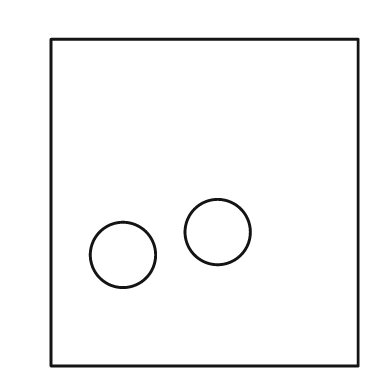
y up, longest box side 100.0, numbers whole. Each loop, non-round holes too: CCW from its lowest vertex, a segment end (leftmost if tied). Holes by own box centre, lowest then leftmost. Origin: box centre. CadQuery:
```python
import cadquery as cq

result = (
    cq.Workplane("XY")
    .moveTo(-47.0, -50.0)
    .lineTo(47.0, -50.0)
    .lineTo(47.0, 50.0)
    .lineTo(-47.0, 50.0)
    .close()
    .moveTo(-25.0, -16.0)
    .circle(10.0)
    .moveTo(4.0, -9.0)
    .circle(10.0)
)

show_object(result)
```